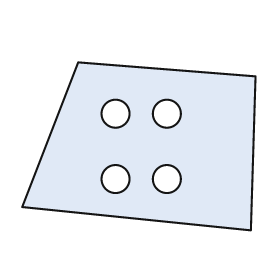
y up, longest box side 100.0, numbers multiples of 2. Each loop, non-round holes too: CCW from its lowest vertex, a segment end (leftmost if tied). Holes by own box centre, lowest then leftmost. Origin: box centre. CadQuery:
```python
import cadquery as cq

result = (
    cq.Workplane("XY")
    .moveTo(48.0, -36.0)
    .lineTo(50.0, 30.0)
    .lineTo(-26.0, 36.0)
    .lineTo(-50.0, -26.0)
    .close()
    .moveTo(-10.0, -14.0)
    .circle(6.0)
    .moveTo(12.0, -14.0)
    .circle(6.0)
    .moveTo(-10.0, 14.0)
    .circle(6.0)
    .moveTo(12.0, 14.0)
    .circle(6.0)
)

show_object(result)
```